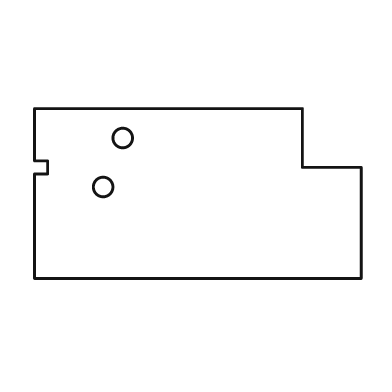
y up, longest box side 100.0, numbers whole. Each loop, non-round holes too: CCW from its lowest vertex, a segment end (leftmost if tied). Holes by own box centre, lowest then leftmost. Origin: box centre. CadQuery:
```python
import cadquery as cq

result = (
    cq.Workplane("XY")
    .moveTo(-50.0, -26.0)
    .lineTo(50.0, -26.0)
    .lineTo(50.0, 8.0)
    .lineTo(32.0, 8.0)
    .lineTo(32.0, 26.0)
    .lineTo(-50.0, 26.0)
    .lineTo(-50.0, 10.0)
    .lineTo(-46.0, 10.0)
    .lineTo(-46.0, 6.0)
    .lineTo(-50.0, 6.0)
    .close()
    .moveTo(-29.0, 2.0)
    .circle(3.0)
    .moveTo(-23.0, 17.0)
    .circle(3.0)
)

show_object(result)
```